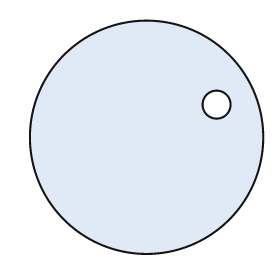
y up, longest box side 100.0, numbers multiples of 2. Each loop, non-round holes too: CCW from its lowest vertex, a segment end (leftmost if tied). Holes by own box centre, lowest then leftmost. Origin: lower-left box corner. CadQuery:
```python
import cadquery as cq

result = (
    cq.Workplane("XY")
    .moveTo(50.0, 50.0)
    .circle(50.0)
    .moveTo(80.0, 64.0)
    .circle(6.0)
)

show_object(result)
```